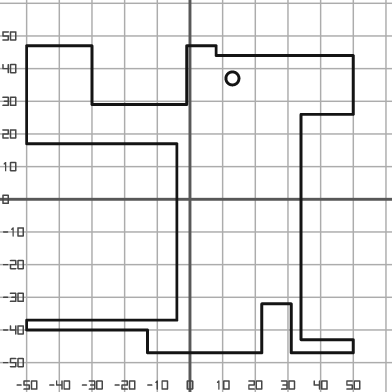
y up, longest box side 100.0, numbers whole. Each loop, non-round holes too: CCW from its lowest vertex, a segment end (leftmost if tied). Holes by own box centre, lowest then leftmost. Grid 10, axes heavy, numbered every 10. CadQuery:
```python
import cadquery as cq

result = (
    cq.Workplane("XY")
    .moveTo(-13.0, -47.0)
    .lineTo(22.0, -47.0)
    .lineTo(22.0, -32.0)
    .lineTo(31.0, -32.0)
    .lineTo(31.0, -47.0)
    .lineTo(50.0, -47.0)
    .lineTo(50.0, -43.0)
    .lineTo(34.0, -43.0)
    .lineTo(34.0, 26.0)
    .lineTo(50.0, 26.0)
    .lineTo(50.0, 44.0)
    .lineTo(8.0, 44.0)
    .lineTo(8.0, 47.0)
    .lineTo(-1.0, 47.0)
    .lineTo(-1.0, 29.0)
    .lineTo(-30.0, 29.0)
    .lineTo(-30.0, 47.0)
    .lineTo(-50.0, 47.0)
    .lineTo(-50.0, 17.0)
    .lineTo(-4.0, 17.0)
    .lineTo(-4.0, -37.0)
    .lineTo(-50.0, -37.0)
    .lineTo(-50.0, -40.0)
    .lineTo(-13.0, -40.0)
    .close()
    .moveTo(13.0, 37.0)
    .circle(2.0)
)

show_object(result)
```